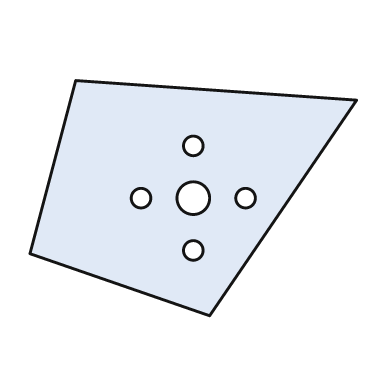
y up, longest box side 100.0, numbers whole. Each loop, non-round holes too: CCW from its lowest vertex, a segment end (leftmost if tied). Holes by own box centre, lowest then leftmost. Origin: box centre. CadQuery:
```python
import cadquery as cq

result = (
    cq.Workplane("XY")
    .moveTo(5.0, -36.0)
    .lineTo(50.0, 30.0)
    .lineTo(-36.0, 36.0)
    .lineTo(-50.0, -17.0)
    .close()
    .moveTo(0.0, -16.0)
    .circle(3.0)
    .moveTo(-16.0, 0.0)
    .circle(3.0)
    .moveTo(0.0, 0.0)
    .circle(5.0)
    .moveTo(16.0, 0.0)
    .circle(3.0)
    .moveTo(0.0, 16.0)
    .circle(3.0)
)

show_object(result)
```